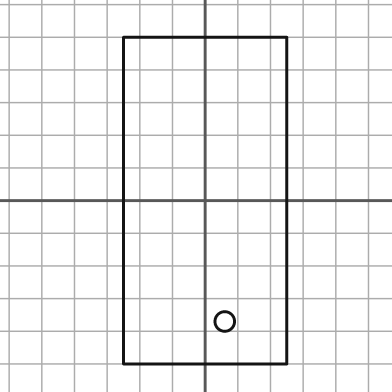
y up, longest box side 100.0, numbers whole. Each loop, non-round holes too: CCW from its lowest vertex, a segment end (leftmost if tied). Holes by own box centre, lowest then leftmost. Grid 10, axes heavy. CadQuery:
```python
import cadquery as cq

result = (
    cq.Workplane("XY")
    .moveTo(-25.0, -50.0)
    .lineTo(25.0, -50.0)
    .lineTo(25.0, 50.0)
    .lineTo(-25.0, 50.0)
    .close()
    .moveTo(6.0, -37.0)
    .circle(3.0)
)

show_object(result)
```